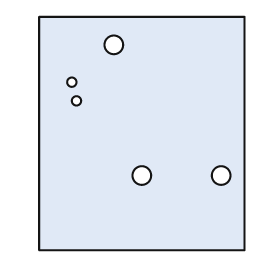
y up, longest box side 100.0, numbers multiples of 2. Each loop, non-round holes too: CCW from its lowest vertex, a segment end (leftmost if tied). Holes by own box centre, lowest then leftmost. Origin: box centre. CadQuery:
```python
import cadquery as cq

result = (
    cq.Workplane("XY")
    .moveTo(-44.0, -50.0)
    .lineTo(44.0, -50.0)
    .lineTo(44.0, 50.0)
    .lineTo(-44.0, 50.0)
    .close()
    .moveTo(0.0, -18.0)
    .circle(4.0)
    .moveTo(34.0, -18.0)
    .circle(4.0)
    .moveTo(-28.0, 14.0)
    .circle(2.0)
    .moveTo(-30.0, 22.0)
    .circle(2.0)
    .moveTo(-12.0, 38.0)
    .circle(4.0)
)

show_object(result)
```